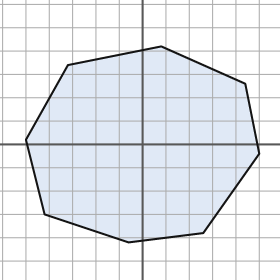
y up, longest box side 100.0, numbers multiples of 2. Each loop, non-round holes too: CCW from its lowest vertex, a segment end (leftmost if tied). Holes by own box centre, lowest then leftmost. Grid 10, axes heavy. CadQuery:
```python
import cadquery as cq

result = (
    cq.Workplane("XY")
    .moveTo(-6.0, -42.0)
    .lineTo(26.0, -38.0)
    .lineTo(50.0, -4.0)
    .lineTo(44.0, 26.0)
    .lineTo(8.0, 42.0)
    .lineTo(-32.0, 34.0)
    .lineTo(-50.0, 2.0)
    .lineTo(-42.0, -30.0)
    .close()
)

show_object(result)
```